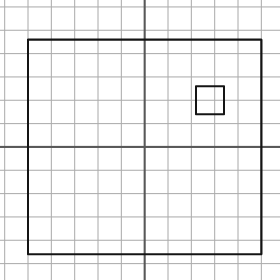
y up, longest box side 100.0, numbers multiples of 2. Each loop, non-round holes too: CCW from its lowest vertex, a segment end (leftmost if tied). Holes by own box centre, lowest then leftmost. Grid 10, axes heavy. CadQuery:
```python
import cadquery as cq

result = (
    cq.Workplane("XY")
    .moveTo(-50.0, -46.0)
    .lineTo(50.0, -46.0)
    .lineTo(50.0, 46.0)
    .lineTo(-50.0, 46.0)
    .close()
    .moveTo(22.0, 14.0)
    .lineTo(34.0, 14.0)
    .lineTo(34.0, 26.0)
    .lineTo(22.0, 26.0)
    .close()
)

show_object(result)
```